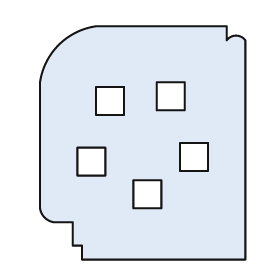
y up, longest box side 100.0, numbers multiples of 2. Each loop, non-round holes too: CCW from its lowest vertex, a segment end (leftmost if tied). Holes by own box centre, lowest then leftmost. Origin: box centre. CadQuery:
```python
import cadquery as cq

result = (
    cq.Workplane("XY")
    .moveTo(-26.0, -50.0)
    .lineTo(44.0, -50.0)
    .lineTo(44.0, 44.0)
    .threePointArc((40.0, 46.0), (36.0, 44.0))
    .lineTo(36.0, 50.0)
    .lineTo(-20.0, 50.0)
    .threePointArc((-36.0, 42.0), (-44.0, 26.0))
    .lineTo(-44.0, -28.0)
    .threePointArc((-42.0, -32.0), (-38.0, -34.0))
    .lineTo(-30.0, -34.0)
    .lineTo(-30.0, -44.0)
    .lineTo(-26.0, -44.0)
    .close()
    .moveTo(-4.0, -28.0)
    .lineTo(8.0, -28.0)
    .lineTo(8.0, -16.0)
    .lineTo(-4.0, -16.0)
    .close()
    .moveTo(-28.0, -14.0)
    .lineTo(-16.0, -14.0)
    .lineTo(-16.0, -2.0)
    .lineTo(-28.0, -2.0)
    .close()
    .moveTo(16.0, -12.0)
    .lineTo(28.0, -12.0)
    .lineTo(28.0, 0.0)
    .lineTo(16.0, 0.0)
    .close()
    .moveTo(-20.0, 12.0)
    .lineTo(-8.0, 12.0)
    .lineTo(-8.0, 24.0)
    .lineTo(-20.0, 24.0)
    .close()
    .moveTo(6.0, 14.0)
    .lineTo(18.0, 14.0)
    .lineTo(18.0, 26.0)
    .lineTo(6.0, 26.0)
    .close()
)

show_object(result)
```